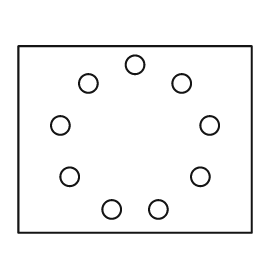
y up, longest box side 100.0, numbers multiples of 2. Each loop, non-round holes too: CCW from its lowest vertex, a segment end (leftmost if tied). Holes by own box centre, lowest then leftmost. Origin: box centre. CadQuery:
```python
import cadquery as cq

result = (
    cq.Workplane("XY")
    .moveTo(-50.0, -40.0)
    .lineTo(50.0, -40.0)
    .lineTo(50.0, 40.0)
    .lineTo(-50.0, 40.0)
    .close()
    .moveTo(-10.0, -30.0)
    .circle(4.0)
    .moveTo(10.0, -30.0)
    .circle(4.0)
    .moveTo(-28.0, -16.0)
    .circle(4.0)
    .moveTo(28.0, -16.0)
    .circle(4.0)
    .moveTo(-32.0, 6.0)
    .circle(4.0)
    .moveTo(32.0, 6.0)
    .circle(4.0)
    .moveTo(-20.0, 24.0)
    .circle(4.0)
    .moveTo(20.0, 24.0)
    .circle(4.0)
    .moveTo(0.0, 32.0)
    .circle(4.0)
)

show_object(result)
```